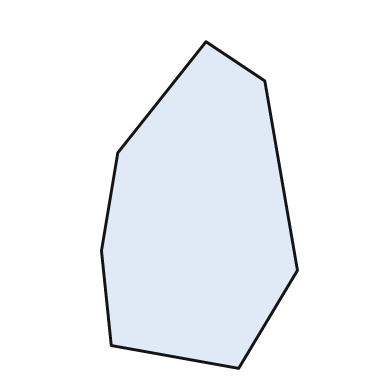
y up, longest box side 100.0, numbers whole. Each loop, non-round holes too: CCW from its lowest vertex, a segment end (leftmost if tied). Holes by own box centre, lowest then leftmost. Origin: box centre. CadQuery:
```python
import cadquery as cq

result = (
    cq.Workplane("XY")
    .moveTo(12.0, -50.0)
    .lineTo(30.0, -20.0)
    .lineTo(20.0, 38.0)
    .lineTo(2.0, 50.0)
    .lineTo(-25.0, 16.0)
    .lineTo(-30.0, -14.0)
    .lineTo(-27.0, -43.0)
    .close()
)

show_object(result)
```